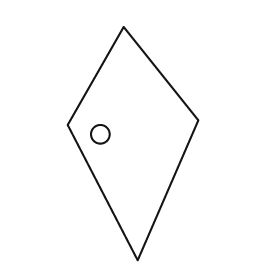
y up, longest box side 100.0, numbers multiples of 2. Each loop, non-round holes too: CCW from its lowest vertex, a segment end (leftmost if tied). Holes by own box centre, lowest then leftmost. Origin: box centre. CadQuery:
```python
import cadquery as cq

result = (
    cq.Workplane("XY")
    .moveTo(2.0, -50.0)
    .lineTo(28.0, 10.0)
    .lineTo(-4.0, 50.0)
    .lineTo(-28.0, 8.0)
    .close()
    .moveTo(-14.0, 4.0)
    .circle(4.0)
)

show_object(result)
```